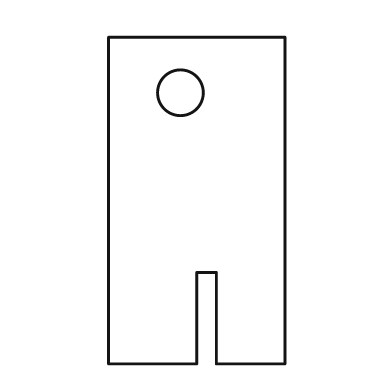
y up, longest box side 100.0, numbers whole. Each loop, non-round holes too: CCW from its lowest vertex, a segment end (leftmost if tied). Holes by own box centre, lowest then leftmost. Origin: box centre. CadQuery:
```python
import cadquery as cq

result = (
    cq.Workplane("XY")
    .moveTo(-27.0, -50.0)
    .lineTo(0.0, -50.0)
    .lineTo(0.0, -22.0)
    .lineTo(6.0, -22.0)
    .lineTo(6.0, -50.0)
    .lineTo(27.0, -50.0)
    .lineTo(27.0, 50.0)
    .lineTo(-27.0, 50.0)
    .close()
    .moveTo(-5.0, 33.0)
    .circle(7.0)
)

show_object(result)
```